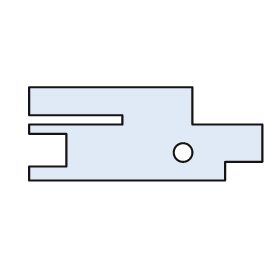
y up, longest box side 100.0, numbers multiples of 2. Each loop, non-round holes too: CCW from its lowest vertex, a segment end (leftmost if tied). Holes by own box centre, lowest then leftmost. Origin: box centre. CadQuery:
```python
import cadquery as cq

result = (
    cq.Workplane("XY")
    .moveTo(-50.0, -20.0)
    .lineTo(34.0, -20.0)
    .lineTo(34.0, -12.0)
    .lineTo(50.0, -12.0)
    .lineTo(50.0, 4.0)
    .lineTo(20.0, 4.0)
    .lineTo(20.0, 20.0)
    .lineTo(-50.0, 20.0)
    .lineTo(-50.0, 8.0)
    .lineTo(-10.0, 8.0)
    .lineTo(-10.0, 4.0)
    .lineTo(-50.0, 4.0)
    .lineTo(-50.0, 0.0)
    .lineTo(-34.0, 0.0)
    .lineTo(-34.0, -14.0)
    .lineTo(-50.0, -14.0)
    .close()
    .moveTo(16.0, -8.0)
    .circle(4.0)
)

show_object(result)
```